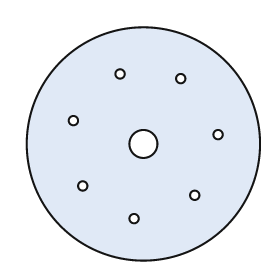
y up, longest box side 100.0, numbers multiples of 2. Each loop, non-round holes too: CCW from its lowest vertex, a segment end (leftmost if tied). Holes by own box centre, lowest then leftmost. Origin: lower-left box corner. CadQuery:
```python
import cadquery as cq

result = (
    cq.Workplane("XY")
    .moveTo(50.0, 50.0)
    .circle(50.0)
    .moveTo(46.0, 18.0)
    .circle(2.0)
    .moveTo(72.0, 28.0)
    .circle(2.0)
    .moveTo(24.0, 32.0)
    .circle(2.0)
    .moveTo(50.0, 50.0)
    .circle(6.0)
    .moveTo(82.0, 54.0)
    .circle(2.0)
    .moveTo(20.0, 60.0)
    .circle(2.0)
    .moveTo(66.0, 78.0)
    .circle(2.0)
    .moveTo(40.0, 80.0)
    .circle(2.0)
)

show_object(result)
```